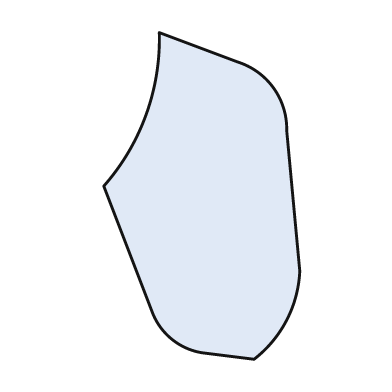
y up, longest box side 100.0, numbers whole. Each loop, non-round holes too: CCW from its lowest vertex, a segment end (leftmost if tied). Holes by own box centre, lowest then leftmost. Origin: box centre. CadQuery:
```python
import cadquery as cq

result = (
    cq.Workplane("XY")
    .moveTo(16.0, -50.0)
    .threePointArc((26.0, -38.0), (30.0, -23.0))
    .lineTo(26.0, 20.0)
    .threePointArc((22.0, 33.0), (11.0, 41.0))
    .lineTo(-13.0, 50.0)
    .threePointArc((-17.0, 25.0), (-30.0, 3.0))
    .lineTo(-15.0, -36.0)
    .threePointArc((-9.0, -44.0), (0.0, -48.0))
    .close()
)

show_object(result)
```